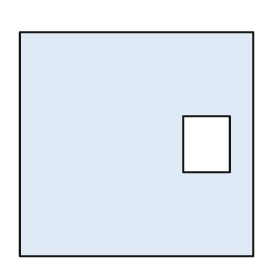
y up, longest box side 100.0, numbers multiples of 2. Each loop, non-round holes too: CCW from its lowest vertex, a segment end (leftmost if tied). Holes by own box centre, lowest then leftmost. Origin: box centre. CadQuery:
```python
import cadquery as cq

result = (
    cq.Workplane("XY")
    .moveTo(-50.0, -48.0)
    .lineTo(50.0, -48.0)
    .lineTo(50.0, 48.0)
    .lineTo(-50.0, 48.0)
    .close()
    .moveTo(20.0, -12.0)
    .lineTo(40.0, -12.0)
    .lineTo(40.0, 12.0)
    .lineTo(20.0, 12.0)
    .close()
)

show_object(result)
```